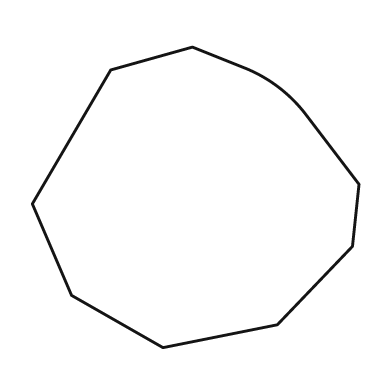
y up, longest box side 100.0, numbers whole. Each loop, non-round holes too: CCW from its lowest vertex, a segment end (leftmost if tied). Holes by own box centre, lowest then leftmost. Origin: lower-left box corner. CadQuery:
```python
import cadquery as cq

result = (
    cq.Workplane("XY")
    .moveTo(40.0, 0.0)
    .lineTo(75.0, 7.0)
    .lineTo(98.0, 31.0)
    .lineTo(100.0, 50.0)
    .lineTo(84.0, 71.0)
    .threePointArc((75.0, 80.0), (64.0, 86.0))
    .lineTo(49.0, 92.0)
    .lineTo(24.0, 85.0)
    .lineTo(0.0, 44.0)
    .lineTo(12.0, 16.0)
    .close()
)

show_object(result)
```